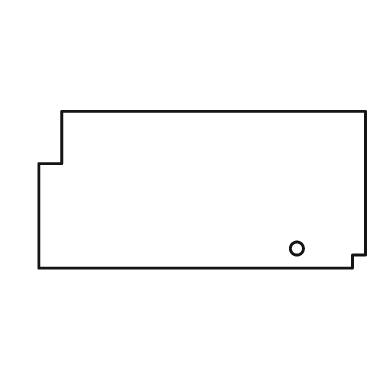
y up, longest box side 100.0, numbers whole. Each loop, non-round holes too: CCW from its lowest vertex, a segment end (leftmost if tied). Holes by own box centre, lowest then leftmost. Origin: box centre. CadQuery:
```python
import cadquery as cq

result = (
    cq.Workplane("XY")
    .moveTo(-50.0, -24.0)
    .lineTo(46.0, -24.0)
    .lineTo(46.0, -20.0)
    .lineTo(50.0, -20.0)
    .lineTo(50.0, 24.0)
    .lineTo(-43.0, 24.0)
    .lineTo(-43.0, 8.0)
    .lineTo(-50.0, 8.0)
    .close()
    .moveTo(29.0, -18.0)
    .circle(2.0)
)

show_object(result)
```